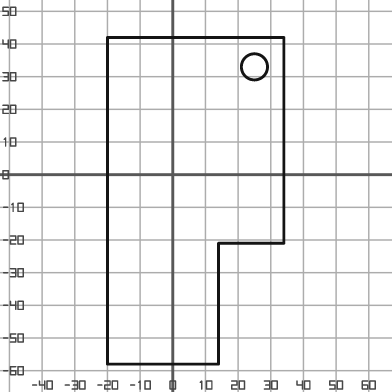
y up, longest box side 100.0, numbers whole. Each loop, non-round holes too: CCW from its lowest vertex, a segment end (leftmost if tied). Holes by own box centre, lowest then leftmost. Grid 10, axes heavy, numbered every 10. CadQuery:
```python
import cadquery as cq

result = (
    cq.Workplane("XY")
    .moveTo(-20.0, -58.0)
    .lineTo(14.0, -58.0)
    .lineTo(14.0, -21.0)
    .lineTo(34.0, -21.0)
    .lineTo(34.0, 42.0)
    .lineTo(-20.0, 42.0)
    .close()
    .moveTo(25.0, 33.0)
    .circle(4.0)
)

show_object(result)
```